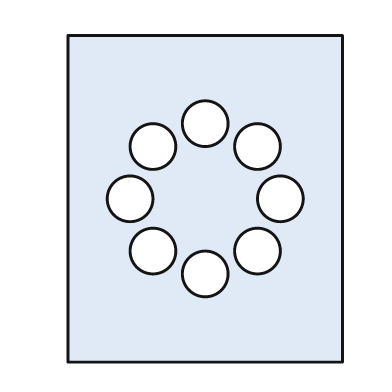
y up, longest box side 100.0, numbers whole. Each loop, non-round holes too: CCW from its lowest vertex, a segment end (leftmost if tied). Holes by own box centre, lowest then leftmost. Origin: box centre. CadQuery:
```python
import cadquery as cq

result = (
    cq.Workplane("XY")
    .moveTo(-42.0, -50.0)
    .lineTo(42.0, -50.0)
    .lineTo(42.0, 50.0)
    .lineTo(-42.0, 50.0)
    .close()
    .moveTo(0.0, -23.0)
    .circle(7.0)
    .moveTo(-16.0, -16.0)
    .circle(7.0)
    .moveTo(16.0, -16.0)
    .circle(7.0)
    .moveTo(-23.0, 0.0)
    .circle(7.0)
    .moveTo(23.0, 0.0)
    .circle(7.0)
    .moveTo(-16.0, 16.0)
    .circle(7.0)
    .moveTo(16.0, 16.0)
    .circle(7.0)
    .moveTo(0.0, 23.0)
    .circle(7.0)
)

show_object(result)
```